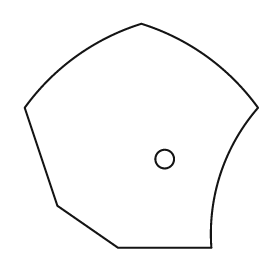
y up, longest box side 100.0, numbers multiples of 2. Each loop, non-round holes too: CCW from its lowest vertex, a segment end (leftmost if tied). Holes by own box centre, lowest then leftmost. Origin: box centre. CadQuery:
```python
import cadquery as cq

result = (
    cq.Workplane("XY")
    .moveTo(-10.0, -48.0)
    .lineTo(30.0, -48.0)
    .threePointArc((34.0, -16.0), (50.0, 12.0))
    .threePointArc((28.0, 34.0), (0.0, 48.0))
    .threePointArc((-28.0, 34.0), (-50.0, 12.0))
    .lineTo(-36.0, -30.0)
    .close()
    .moveTo(10.0, -10.0)
    .circle(4.0)
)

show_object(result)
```